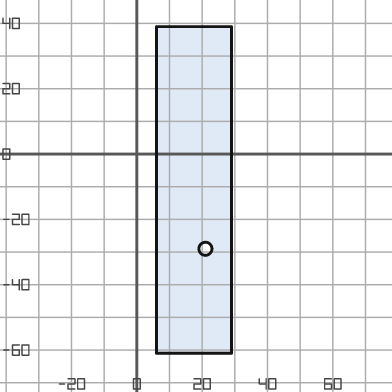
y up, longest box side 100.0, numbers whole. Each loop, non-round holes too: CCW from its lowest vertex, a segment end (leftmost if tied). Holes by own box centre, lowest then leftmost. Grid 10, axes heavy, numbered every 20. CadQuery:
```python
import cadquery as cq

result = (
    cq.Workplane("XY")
    .moveTo(6.0, -61.0)
    .lineTo(29.0, -61.0)
    .lineTo(29.0, 39.0)
    .lineTo(6.0, 39.0)
    .close()
    .moveTo(21.0, -29.0)
    .circle(2.0)
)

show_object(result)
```